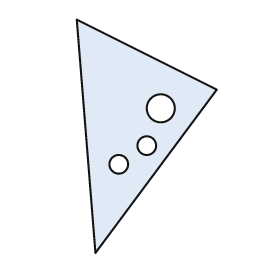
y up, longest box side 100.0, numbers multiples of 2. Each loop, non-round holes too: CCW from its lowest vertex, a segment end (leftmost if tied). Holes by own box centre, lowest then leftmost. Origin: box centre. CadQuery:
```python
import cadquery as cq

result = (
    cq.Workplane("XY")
    .moveTo(-22.0, -50.0)
    .lineTo(30.0, 20.0)
    .lineTo(-30.0, 50.0)
    .close()
    .moveTo(-12.0, -12.0)
    .circle(4.0)
    .moveTo(0.0, -4.0)
    .circle(4.0)
    .moveTo(6.0, 12.0)
    .circle(6.0)
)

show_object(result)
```